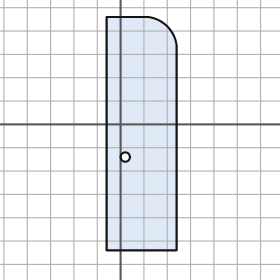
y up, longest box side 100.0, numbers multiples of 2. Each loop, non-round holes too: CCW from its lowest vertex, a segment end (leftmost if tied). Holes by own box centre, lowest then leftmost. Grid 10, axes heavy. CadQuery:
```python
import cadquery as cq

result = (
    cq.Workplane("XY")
    .moveTo(-6.0, -54.0)
    .lineTo(24.0, -54.0)
    .lineTo(24.0, 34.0)
    .threePointArc((20.0, 42.0), (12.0, 46.0))
    .lineTo(-6.0, 46.0)
    .close()
    .moveTo(2.0, -14.0)
    .circle(2.0)
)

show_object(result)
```